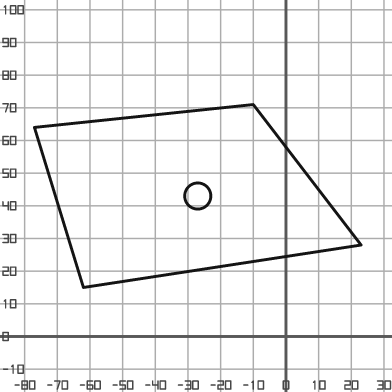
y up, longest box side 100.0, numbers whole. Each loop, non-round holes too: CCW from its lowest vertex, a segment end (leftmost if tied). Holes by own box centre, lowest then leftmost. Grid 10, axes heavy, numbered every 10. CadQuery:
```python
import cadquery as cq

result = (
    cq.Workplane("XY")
    .moveTo(-62.0, 15.0)
    .lineTo(23.0, 28.0)
    .lineTo(-10.0, 71.0)
    .lineTo(-77.0, 64.0)
    .close()
    .moveTo(-27.0, 43.0)
    .circle(4.0)
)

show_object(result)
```